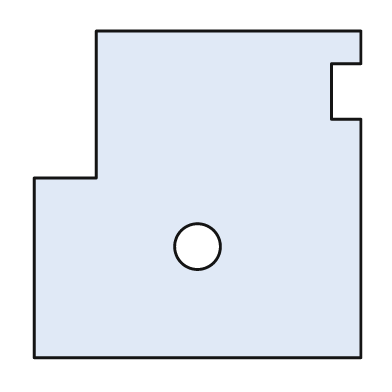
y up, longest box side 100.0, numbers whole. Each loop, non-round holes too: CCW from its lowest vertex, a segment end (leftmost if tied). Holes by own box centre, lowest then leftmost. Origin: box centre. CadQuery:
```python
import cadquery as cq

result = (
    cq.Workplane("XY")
    .moveTo(-50.0, -50.0)
    .lineTo(50.0, -50.0)
    .lineTo(50.0, 23.0)
    .lineTo(41.0, 23.0)
    .lineTo(41.0, 40.0)
    .lineTo(50.0, 40.0)
    .lineTo(50.0, 50.0)
    .lineTo(-31.0, 50.0)
    .lineTo(-31.0, 5.0)
    .lineTo(-50.0, 5.0)
    .close()
    .moveTo(0.0, -16.0)
    .circle(7.0)
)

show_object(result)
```